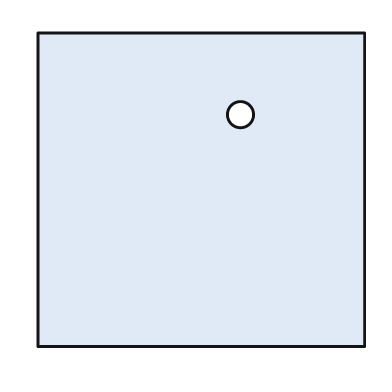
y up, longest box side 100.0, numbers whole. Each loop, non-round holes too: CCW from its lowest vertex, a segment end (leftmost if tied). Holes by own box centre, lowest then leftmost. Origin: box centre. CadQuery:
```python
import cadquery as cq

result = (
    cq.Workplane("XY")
    .moveTo(-50.0, -48.0)
    .lineTo(50.0, -48.0)
    .lineTo(50.0, 48.0)
    .lineTo(-50.0, 48.0)
    .close()
    .moveTo(12.0, 23.0)
    .circle(4.0)
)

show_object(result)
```